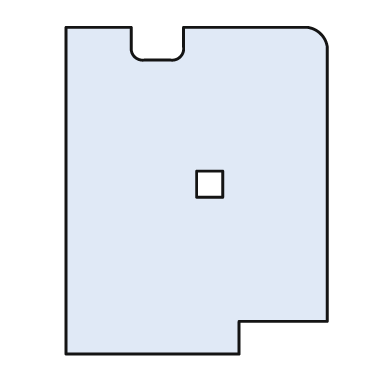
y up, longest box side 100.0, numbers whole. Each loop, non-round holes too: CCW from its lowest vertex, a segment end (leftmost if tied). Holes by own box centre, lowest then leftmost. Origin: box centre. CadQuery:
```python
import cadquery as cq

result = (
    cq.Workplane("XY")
    .moveTo(-40.0, -50.0)
    .lineTo(13.0, -50.0)
    .lineTo(13.0, -40.0)
    .lineTo(40.0, -40.0)
    .lineTo(40.0, 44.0)
    .threePointArc((38.0, 48.0), (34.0, 50.0))
    .lineTo(-4.0, 50.0)
    .lineTo(-4.0, 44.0)
    .threePointArc((-5.0, 41.0), (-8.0, 40.0))
    .lineTo(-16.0, 40.0)
    .threePointArc((-19.0, 41.0), (-20.0, 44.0))
    .lineTo(-20.0, 50.0)
    .lineTo(-40.0, 50.0)
    .close()
    .moveTo(0.0, -2.0)
    .lineTo(8.0, -2.0)
    .lineTo(8.0, 6.0)
    .lineTo(0.0, 6.0)
    .close()
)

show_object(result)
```